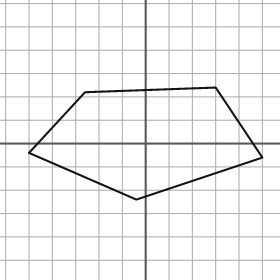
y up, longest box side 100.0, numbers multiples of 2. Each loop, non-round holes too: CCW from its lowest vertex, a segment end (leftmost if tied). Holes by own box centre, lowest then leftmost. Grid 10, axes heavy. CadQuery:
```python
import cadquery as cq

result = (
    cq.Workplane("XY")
    .moveTo(-4.0, -24.0)
    .lineTo(50.0, -6.0)
    .lineTo(30.0, 24.0)
    .lineTo(-26.0, 22.0)
    .lineTo(-50.0, -4.0)
    .close()
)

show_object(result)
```